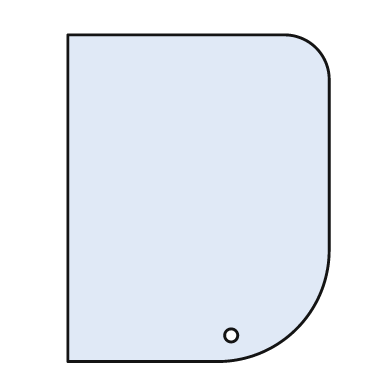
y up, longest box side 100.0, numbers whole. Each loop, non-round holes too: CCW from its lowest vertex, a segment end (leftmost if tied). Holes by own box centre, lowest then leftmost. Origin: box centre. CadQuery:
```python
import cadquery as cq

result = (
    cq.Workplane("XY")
    .moveTo(-40.0, -50.0)
    .lineTo(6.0, -50.0)
    .threePointArc((30.0, -40.0), (40.0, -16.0))
    .lineTo(40.0, 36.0)
    .threePointArc((36.0, 46.0), (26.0, 50.0))
    .lineTo(-40.0, 50.0)
    .close()
    .moveTo(10.0, -42.0)
    .circle(2.0)
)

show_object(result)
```